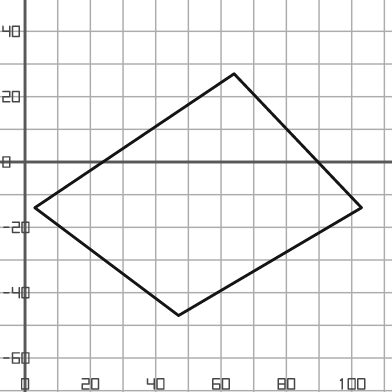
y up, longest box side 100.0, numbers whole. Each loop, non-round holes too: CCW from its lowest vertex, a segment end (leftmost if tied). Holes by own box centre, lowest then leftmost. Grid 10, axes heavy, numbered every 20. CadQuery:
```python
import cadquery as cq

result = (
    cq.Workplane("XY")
    .moveTo(47.0, -47.0)
    .lineTo(103.0, -14.0)
    .lineTo(64.0, 27.0)
    .lineTo(3.0, -14.0)
    .close()
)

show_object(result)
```